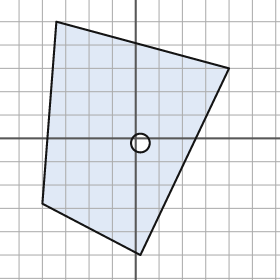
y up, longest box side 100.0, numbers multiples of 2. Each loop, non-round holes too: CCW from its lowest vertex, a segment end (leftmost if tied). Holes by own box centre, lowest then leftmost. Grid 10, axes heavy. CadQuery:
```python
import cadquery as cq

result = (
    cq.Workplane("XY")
    .moveTo(2.0, -50.0)
    .lineTo(40.0, 30.0)
    .lineTo(-34.0, 50.0)
    .lineTo(-40.0, -28.0)
    .close()
    .moveTo(2.0, -2.0)
    .circle(4.0)
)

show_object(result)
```